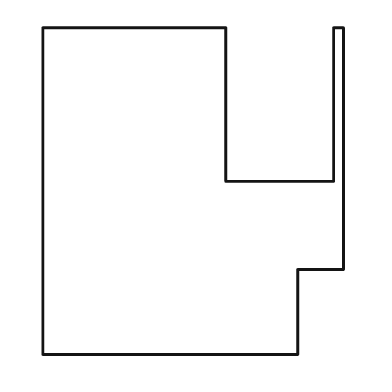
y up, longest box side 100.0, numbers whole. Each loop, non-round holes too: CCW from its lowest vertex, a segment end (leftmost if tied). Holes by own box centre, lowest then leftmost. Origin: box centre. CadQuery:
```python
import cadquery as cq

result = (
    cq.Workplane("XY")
    .moveTo(-46.0, -50.0)
    .lineTo(32.0, -50.0)
    .lineTo(32.0, -24.0)
    .lineTo(46.0, -24.0)
    .lineTo(46.0, 50.0)
    .lineTo(43.0, 50.0)
    .lineTo(43.0, 3.0)
    .lineTo(10.0, 3.0)
    .lineTo(10.0, 50.0)
    .lineTo(-46.0, 50.0)
    .close()
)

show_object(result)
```